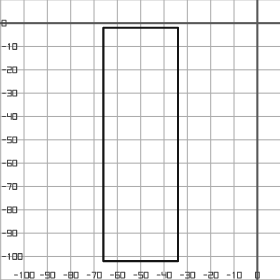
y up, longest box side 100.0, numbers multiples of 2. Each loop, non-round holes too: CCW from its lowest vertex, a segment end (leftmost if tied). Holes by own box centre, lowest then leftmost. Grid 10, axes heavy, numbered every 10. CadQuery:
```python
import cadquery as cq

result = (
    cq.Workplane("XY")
    .moveTo(-66.0, -102.0)
    .lineTo(-34.0, -102.0)
    .lineTo(-34.0, -2.0)
    .lineTo(-66.0, -2.0)
    .close()
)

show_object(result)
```